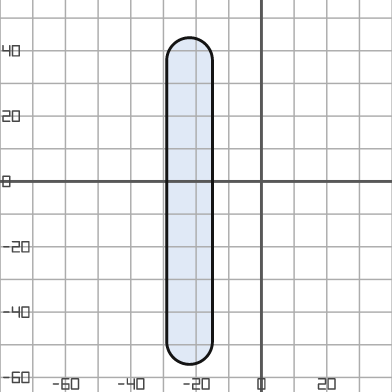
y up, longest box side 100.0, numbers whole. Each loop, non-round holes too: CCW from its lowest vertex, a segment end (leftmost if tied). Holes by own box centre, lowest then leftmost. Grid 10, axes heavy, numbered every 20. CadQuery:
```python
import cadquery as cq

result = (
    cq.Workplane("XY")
    .moveTo(-29.0, -49.0)
    .threePointArc((-22.0, -56.0), (-15.0, -49.0))
    .lineTo(-15.0, 37.0)
    .threePointArc((-22.0, 44.0), (-29.0, 37.0))
    .close()
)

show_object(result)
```